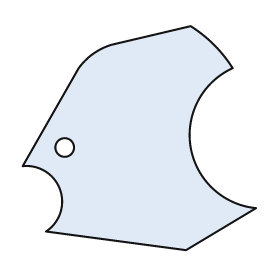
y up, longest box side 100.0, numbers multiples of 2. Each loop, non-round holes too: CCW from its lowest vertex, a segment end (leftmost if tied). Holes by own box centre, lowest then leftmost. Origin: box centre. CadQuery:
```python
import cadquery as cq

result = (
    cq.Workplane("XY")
    .moveTo(20.0, -48.0)
    .lineTo(50.0, -30.0)
    .threePointArc((22.0, -4.0), (40.0, 30.0))
    .threePointArc((32.0, 40.0), (22.0, 48.0))
    .lineTo(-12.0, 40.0)
    .threePointArc((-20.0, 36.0), (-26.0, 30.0))
    .lineTo(-50.0, -12.0)
    .threePointArc((-34.0, -22.0), (-40.0, -40.0))
    .close()
    .moveTo(-32.0, -4.0)
    .circle(4.0)
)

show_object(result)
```